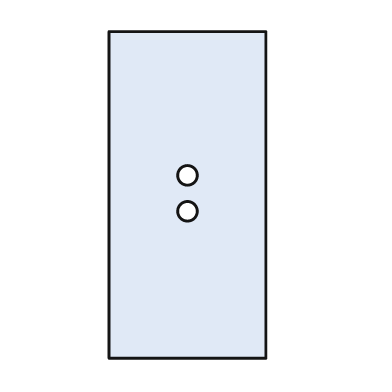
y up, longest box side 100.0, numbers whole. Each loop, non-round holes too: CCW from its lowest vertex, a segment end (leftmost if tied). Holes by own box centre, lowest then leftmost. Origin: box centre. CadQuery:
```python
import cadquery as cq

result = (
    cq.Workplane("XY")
    .moveTo(-24.0, -50.0)
    .lineTo(24.0, -50.0)
    .lineTo(24.0, 50.0)
    .lineTo(-24.0, 50.0)
    .close()
    .moveTo(0.0, -5.0)
    .circle(3.0)
    .moveTo(0.0, 6.0)
    .circle(3.0)
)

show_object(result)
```